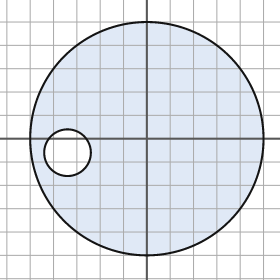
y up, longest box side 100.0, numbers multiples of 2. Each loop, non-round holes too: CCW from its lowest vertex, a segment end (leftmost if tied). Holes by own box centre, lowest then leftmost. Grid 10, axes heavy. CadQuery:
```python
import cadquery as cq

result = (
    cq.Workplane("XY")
    .moveTo(0.0, 0.0)
    .circle(50.0)
    .moveTo(-34.0, -6.0)
    .circle(10.0)
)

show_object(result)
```